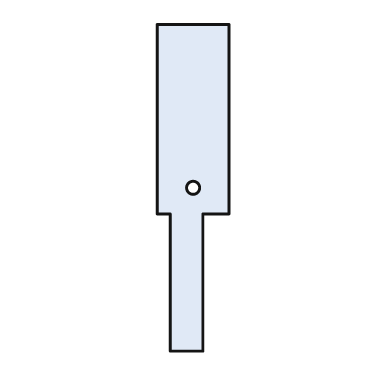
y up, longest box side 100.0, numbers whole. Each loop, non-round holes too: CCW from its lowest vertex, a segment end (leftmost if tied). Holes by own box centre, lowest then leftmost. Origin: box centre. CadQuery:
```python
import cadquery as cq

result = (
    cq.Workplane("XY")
    .moveTo(-7.0, -50.0)
    .lineTo(3.0, -50.0)
    .lineTo(3.0, -8.0)
    .lineTo(11.0, -8.0)
    .lineTo(11.0, 50.0)
    .lineTo(-11.0, 50.0)
    .lineTo(-11.0, -8.0)
    .lineTo(-7.0, -8.0)
    .close()
    .moveTo(0.0, 0.0)
    .circle(2.0)
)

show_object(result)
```